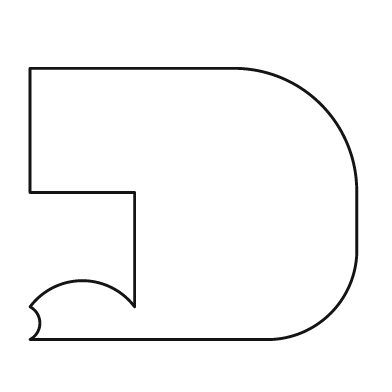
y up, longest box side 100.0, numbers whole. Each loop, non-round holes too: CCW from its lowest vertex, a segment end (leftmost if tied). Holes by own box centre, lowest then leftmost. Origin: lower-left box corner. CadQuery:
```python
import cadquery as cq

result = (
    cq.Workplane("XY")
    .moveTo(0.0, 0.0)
    .lineTo(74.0, 0.0)
    .threePointArc((92.0, 8.0), (100.0, 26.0))
    .lineTo(100.0, 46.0)
    .threePointArc((89.0, 72.0), (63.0, 83.0))
    .lineTo(0.0, 83.0)
    .lineTo(0.0, 45.0)
    .lineTo(32.0, 45.0)
    .lineTo(32.0, 10.0)
    .threePointArc((16.0, 18.0), (0.0, 10.0))
    .threePointArc((3.0, 5.0), (0.0, 0.0))
    .close()
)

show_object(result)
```